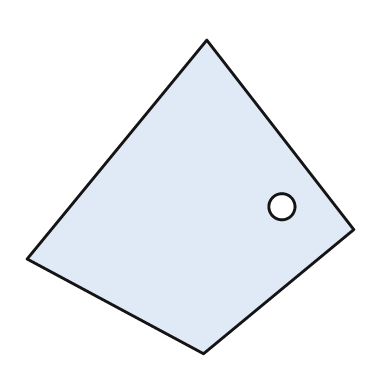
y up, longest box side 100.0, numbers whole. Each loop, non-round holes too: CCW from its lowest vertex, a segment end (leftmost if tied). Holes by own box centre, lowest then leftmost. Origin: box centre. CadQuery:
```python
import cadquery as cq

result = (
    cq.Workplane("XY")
    .moveTo(4.0, -48.0)
    .lineTo(50.0, -10.0)
    .lineTo(5.0, 48.0)
    .lineTo(-50.0, -19.0)
    .close()
    .moveTo(28.0, -3.0)
    .circle(4.0)
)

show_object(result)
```